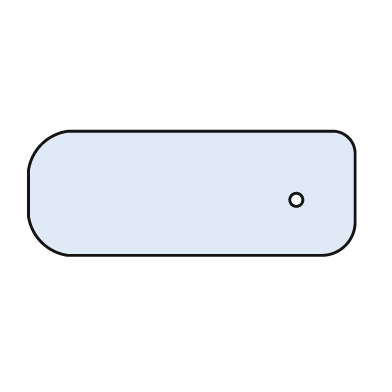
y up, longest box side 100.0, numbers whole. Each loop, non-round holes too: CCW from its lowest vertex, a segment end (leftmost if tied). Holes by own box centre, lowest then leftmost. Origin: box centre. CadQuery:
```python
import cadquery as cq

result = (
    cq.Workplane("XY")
    .moveTo(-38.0, -19.0)
    .lineTo(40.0, -19.0)
    .threePointArc((47.0, -16.0), (50.0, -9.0))
    .lineTo(50.0, 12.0)
    .threePointArc((48.0, 17.0), (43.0, 19.0))
    .lineTo(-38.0, 19.0)
    .threePointArc((-46.0, 15.0), (-50.0, 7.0))
    .lineTo(-50.0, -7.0)
    .threePointArc((-46.0, -15.0), (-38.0, -19.0))
    .close()
    .moveTo(32.0, -2.0)
    .circle(2.0)
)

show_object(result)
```